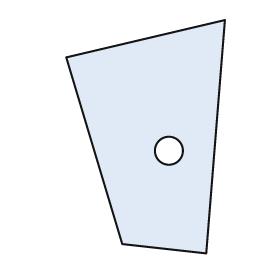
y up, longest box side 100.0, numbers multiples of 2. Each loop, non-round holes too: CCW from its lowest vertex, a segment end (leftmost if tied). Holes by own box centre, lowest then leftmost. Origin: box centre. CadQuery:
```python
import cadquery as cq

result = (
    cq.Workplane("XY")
    .moveTo(26.0, -50.0)
    .lineTo(34.0, 50.0)
    .lineTo(-34.0, 34.0)
    .lineTo(-10.0, -46.0)
    .close()
    .moveTo(10.0, -6.0)
    .circle(6.0)
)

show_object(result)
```